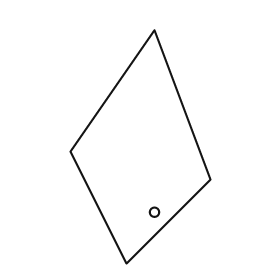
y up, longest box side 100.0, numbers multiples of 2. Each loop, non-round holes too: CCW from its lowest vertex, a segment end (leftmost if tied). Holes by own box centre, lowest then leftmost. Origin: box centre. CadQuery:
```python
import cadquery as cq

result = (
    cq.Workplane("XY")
    .moveTo(-6.0, -50.0)
    .lineTo(30.0, -14.0)
    .lineTo(6.0, 50.0)
    .lineTo(-30.0, -2.0)
    .close()
    .moveTo(6.0, -28.0)
    .circle(2.0)
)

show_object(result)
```